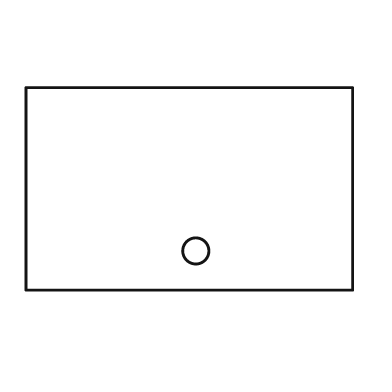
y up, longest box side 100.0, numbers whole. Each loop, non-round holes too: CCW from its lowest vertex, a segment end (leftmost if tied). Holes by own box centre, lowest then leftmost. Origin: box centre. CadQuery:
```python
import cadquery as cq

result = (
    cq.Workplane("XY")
    .moveTo(-50.0, -31.0)
    .lineTo(50.0, -31.0)
    .lineTo(50.0, 31.0)
    .lineTo(-50.0, 31.0)
    .close()
    .moveTo(2.0, -19.0)
    .circle(4.0)
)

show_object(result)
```